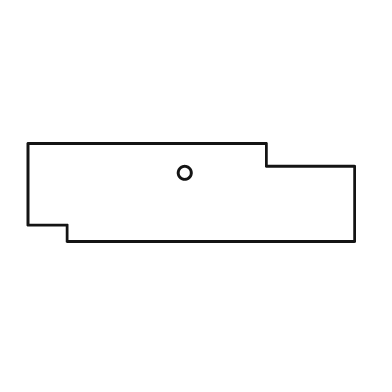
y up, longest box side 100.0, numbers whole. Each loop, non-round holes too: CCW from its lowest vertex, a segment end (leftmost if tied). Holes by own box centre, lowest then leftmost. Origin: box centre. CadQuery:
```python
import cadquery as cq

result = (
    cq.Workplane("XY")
    .moveTo(-38.0, -15.0)
    .lineTo(50.0, -15.0)
    .lineTo(50.0, 8.0)
    .lineTo(23.0, 8.0)
    .lineTo(23.0, 15.0)
    .lineTo(-50.0, 15.0)
    .lineTo(-50.0, -10.0)
    .lineTo(-38.0, -10.0)
    .close()
    .moveTo(-2.0, 6.0)
    .circle(2.0)
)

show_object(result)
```